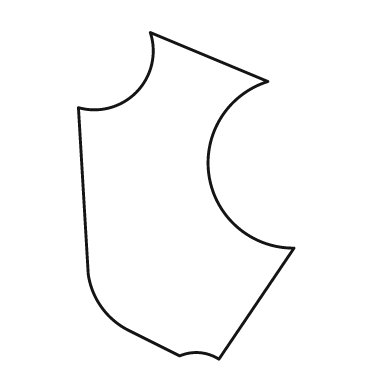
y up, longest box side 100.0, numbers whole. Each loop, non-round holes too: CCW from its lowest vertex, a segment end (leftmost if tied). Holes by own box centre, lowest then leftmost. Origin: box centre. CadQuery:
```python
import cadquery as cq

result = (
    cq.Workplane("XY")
    .moveTo(10.0, -50.0)
    .lineTo(33.0, -16.0)
    .threePointArc((7.0, 6.0), (25.0, 35.0))
    .lineTo(-11.0, 50.0)
    .threePointArc((-15.0, 32.0), (-33.0, 27.0))
    .lineTo(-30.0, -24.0)
    .threePointArc((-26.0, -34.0), (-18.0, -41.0))
    .lineTo(-2.0, -49.0)
    .threePointArc((4.0, -48.0), (10.0, -50.0))
    .close()
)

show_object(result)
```